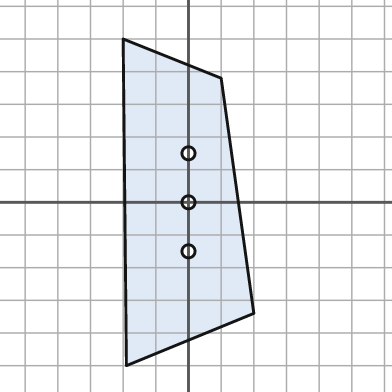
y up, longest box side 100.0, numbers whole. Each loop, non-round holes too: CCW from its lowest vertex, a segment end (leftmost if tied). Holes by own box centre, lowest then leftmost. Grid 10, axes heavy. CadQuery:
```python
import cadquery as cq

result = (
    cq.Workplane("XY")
    .moveTo(-19.0, -50.0)
    .lineTo(20.0, -34.0)
    .lineTo(10.0, 38.0)
    .lineTo(-20.0, 50.0)
    .close()
    .moveTo(0.0, -15.0)
    .circle(2.0)
    .moveTo(0.0, 0.0)
    .circle(2.0)
    .moveTo(0.0, 15.0)
    .circle(2.0)
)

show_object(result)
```